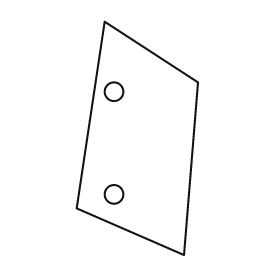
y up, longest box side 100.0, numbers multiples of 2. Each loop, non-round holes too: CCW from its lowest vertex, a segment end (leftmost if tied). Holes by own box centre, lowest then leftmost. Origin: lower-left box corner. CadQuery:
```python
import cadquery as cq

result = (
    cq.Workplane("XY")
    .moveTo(46.0, 0.0)
    .lineTo(52.0, 74.0)
    .lineTo(12.0, 100.0)
    .lineTo(0.0, 20.0)
    .close()
    .moveTo(16.0, 26.0)
    .circle(4.0)
    .moveTo(16.0, 70.0)
    .circle(4.0)
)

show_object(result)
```